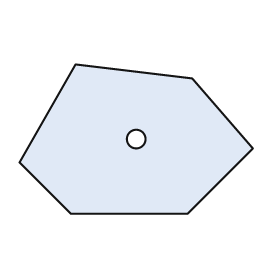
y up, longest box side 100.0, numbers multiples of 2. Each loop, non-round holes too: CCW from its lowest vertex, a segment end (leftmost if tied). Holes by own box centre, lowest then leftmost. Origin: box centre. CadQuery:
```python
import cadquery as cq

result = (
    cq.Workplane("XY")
    .moveTo(-28.0, -32.0)
    .lineTo(22.0, -32.0)
    .lineTo(50.0, -4.0)
    .lineTo(24.0, 26.0)
    .lineTo(-26.0, 32.0)
    .lineTo(-50.0, -10.0)
    .close()
    .moveTo(0.0, 0.0)
    .circle(4.0)
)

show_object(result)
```